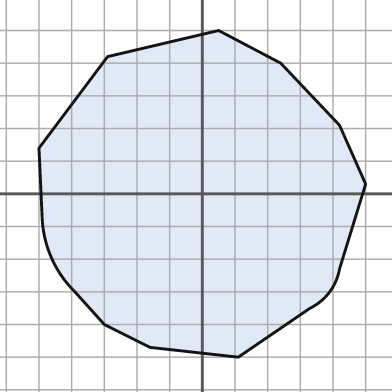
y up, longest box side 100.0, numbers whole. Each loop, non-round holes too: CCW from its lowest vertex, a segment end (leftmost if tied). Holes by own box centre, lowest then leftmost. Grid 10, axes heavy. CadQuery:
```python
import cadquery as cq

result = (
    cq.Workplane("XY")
    .moveTo(11.0, -50.0)
    .lineTo(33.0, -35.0)
    .threePointArc((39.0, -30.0), (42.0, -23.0))
    .lineTo(50.0, 3.0)
    .lineTo(42.0, 21.0)
    .lineTo(24.0, 40.0)
    .lineTo(5.0, 50.0)
    .lineTo(-29.0, 42.0)
    .lineTo(-50.0, 14.0)
    .lineTo(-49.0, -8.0)
    .threePointArc((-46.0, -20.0), (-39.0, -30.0))
    .lineTo(-30.0, -40.0)
    .lineTo(-16.0, -47.0)
    .close()
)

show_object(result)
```